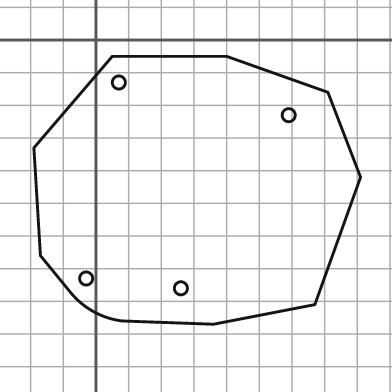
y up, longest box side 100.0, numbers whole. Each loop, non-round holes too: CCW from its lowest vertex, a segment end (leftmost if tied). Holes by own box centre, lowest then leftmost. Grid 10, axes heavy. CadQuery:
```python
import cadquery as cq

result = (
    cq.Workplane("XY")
    .moveTo(36.0, -87.0)
    .lineTo(67.0, -81.0)
    .lineTo(81.0, -42.0)
    .lineTo(71.0, -16.0)
    .lineTo(40.0, -5.0)
    .lineTo(5.0, -5.0)
    .lineTo(-19.0, -33.0)
    .lineTo(-17.0, -66.0)
    .lineTo(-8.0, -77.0)
    .threePointArc((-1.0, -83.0), (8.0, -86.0))
    .close()
    .moveTo(26.0, -76.0)
    .circle(2.0)
    .moveTo(-3.0, -73.0)
    .circle(2.0)
    .moveTo(59.0, -23.0)
    .circle(2.0)
    .moveTo(7.0, -13.0)
    .circle(2.0)
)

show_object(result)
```